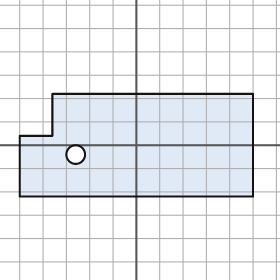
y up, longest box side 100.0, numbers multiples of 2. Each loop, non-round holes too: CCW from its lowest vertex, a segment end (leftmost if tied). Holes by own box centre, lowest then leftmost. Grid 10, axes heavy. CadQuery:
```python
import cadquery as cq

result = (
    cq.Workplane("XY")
    .moveTo(-50.0, -22.0)
    .lineTo(50.0, -22.0)
    .lineTo(50.0, 22.0)
    .lineTo(-36.0, 22.0)
    .lineTo(-36.0, 4.0)
    .lineTo(-50.0, 4.0)
    .close()
    .moveTo(-26.0, -4.0)
    .circle(4.0)
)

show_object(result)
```